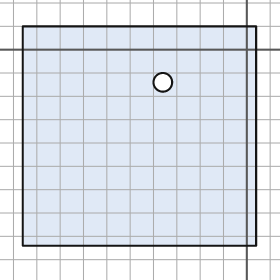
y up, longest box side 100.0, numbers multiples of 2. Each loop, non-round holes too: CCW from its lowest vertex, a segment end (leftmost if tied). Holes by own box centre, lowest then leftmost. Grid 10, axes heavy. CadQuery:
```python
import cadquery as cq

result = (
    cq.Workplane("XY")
    .moveTo(-96.0, -84.0)
    .lineTo(4.0, -84.0)
    .lineTo(4.0, 10.0)
    .lineTo(-96.0, 10.0)
    .close()
    .moveTo(-36.0, -14.0)
    .circle(4.0)
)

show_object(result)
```